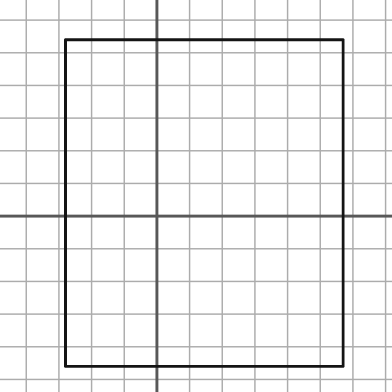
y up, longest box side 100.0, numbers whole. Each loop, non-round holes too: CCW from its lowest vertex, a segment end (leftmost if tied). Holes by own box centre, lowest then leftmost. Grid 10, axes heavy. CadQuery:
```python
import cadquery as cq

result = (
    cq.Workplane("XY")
    .moveTo(-28.0, -46.0)
    .lineTo(57.0, -46.0)
    .lineTo(57.0, 54.0)
    .lineTo(-28.0, 54.0)
    .close()
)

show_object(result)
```